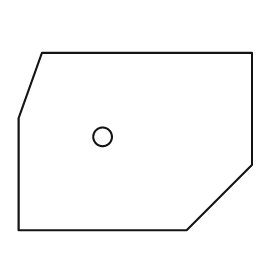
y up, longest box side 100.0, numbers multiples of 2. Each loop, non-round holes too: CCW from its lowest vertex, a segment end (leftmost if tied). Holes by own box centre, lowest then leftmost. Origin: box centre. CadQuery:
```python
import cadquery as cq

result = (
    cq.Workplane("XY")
    .moveTo(-50.0, -38.0)
    .lineTo(22.0, -38.0)
    .lineTo(50.0, -10.0)
    .lineTo(50.0, 38.0)
    .lineTo(-40.0, 38.0)
    .lineTo(-50.0, 10.0)
    .close()
    .moveTo(-14.0, 2.0)
    .circle(4.0)
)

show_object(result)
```